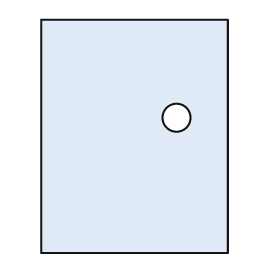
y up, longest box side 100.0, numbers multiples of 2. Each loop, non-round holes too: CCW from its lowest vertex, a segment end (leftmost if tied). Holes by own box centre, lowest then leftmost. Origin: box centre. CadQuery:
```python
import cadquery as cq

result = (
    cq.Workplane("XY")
    .moveTo(-40.0, -50.0)
    .lineTo(40.0, -50.0)
    .lineTo(40.0, 50.0)
    .lineTo(-40.0, 50.0)
    .close()
    .moveTo(18.0, 8.0)
    .circle(6.0)
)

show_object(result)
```